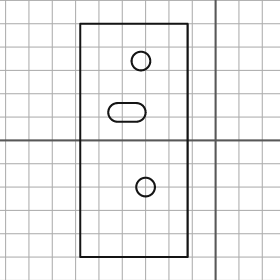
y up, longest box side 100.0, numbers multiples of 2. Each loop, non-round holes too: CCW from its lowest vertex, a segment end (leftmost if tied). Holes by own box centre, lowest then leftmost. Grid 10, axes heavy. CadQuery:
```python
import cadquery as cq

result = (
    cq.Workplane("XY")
    .moveTo(-58.0, -50.0)
    .lineTo(-12.0, -50.0)
    .lineTo(-12.0, 50.0)
    .lineTo(-58.0, 50.0)
    .close()
    .moveTo(-30.0, -20.0)
    .circle(4.0)
    .moveTo(-42.0, 8.0)
    .lineTo(-34.0, 8.0)
    .threePointArc((-30.0, 12.0), (-34.0, 16.0))
    .lineTo(-42.0, 16.0)
    .threePointArc((-46.0, 12.0), (-42.0, 8.0))
    .close()
    .moveTo(-32.0, 34.0)
    .circle(4.0)
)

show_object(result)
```